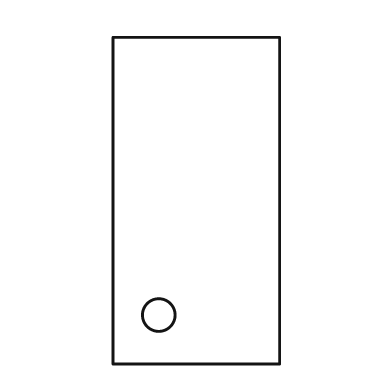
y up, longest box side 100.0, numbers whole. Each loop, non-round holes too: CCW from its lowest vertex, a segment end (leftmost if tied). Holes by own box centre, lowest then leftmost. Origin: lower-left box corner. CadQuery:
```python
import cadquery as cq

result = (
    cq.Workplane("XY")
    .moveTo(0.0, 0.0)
    .lineTo(51.0, 0.0)
    .lineTo(51.0, 100.0)
    .lineTo(0.0, 100.0)
    .close()
    .moveTo(14.0, 15.0)
    .circle(5.0)
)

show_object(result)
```